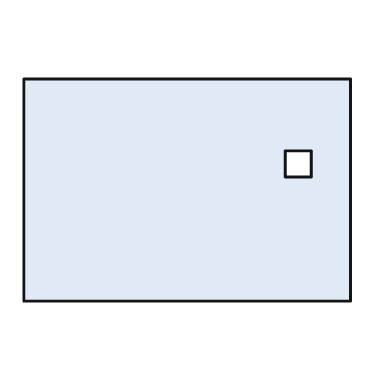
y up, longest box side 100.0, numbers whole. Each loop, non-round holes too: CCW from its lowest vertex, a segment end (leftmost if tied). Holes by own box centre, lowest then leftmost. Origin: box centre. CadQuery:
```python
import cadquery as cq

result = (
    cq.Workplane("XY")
    .moveTo(-50.0, -34.0)
    .lineTo(50.0, -34.0)
    .lineTo(50.0, 34.0)
    .lineTo(-50.0, 34.0)
    .close()
    .moveTo(30.0, 4.0)
    .lineTo(38.0, 4.0)
    .lineTo(38.0, 12.0)
    .lineTo(30.0, 12.0)
    .close()
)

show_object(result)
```